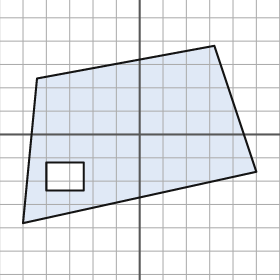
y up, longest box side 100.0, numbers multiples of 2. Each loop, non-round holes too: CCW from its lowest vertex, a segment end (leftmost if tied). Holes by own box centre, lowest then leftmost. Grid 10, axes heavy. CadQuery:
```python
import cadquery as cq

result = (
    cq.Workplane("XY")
    .moveTo(-50.0, -38.0)
    .lineTo(50.0, -16.0)
    .lineTo(32.0, 38.0)
    .lineTo(-44.0, 24.0)
    .close()
    .moveTo(-40.0, -24.0)
    .lineTo(-24.0, -24.0)
    .lineTo(-24.0, -12.0)
    .lineTo(-40.0, -12.0)
    .close()
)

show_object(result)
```